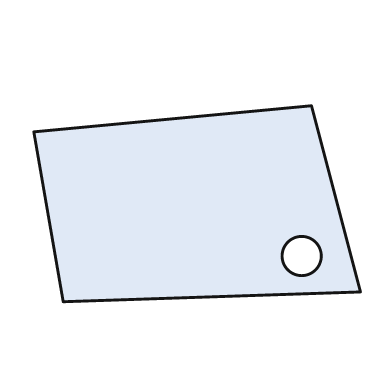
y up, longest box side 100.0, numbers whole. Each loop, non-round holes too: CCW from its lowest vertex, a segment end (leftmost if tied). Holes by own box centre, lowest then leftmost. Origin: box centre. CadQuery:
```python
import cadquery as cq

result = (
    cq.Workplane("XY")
    .moveTo(-41.0, -30.0)
    .lineTo(50.0, -27.0)
    .lineTo(35.0, 30.0)
    .lineTo(-50.0, 22.0)
    .close()
    .moveTo(32.0, -16.0)
    .circle(6.0)
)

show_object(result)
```